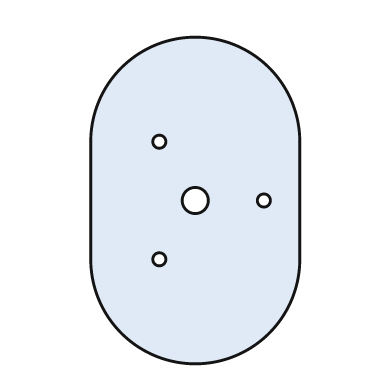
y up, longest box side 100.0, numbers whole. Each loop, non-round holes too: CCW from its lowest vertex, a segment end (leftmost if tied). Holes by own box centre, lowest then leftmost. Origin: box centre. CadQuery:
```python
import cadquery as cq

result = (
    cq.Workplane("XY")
    .moveTo(-32.0, -18.0)
    .threePointArc((0.0, -50.0), (32.0, -18.0))
    .lineTo(32.0, 18.0)
    .threePointArc((0.0, 50.0), (-32.0, 18.0))
    .close()
    .moveTo(-11.0, -18.0)
    .circle(2.0)
    .moveTo(0.0, 0.0)
    .circle(4.0)
    .moveTo(21.0, 0.0)
    .circle(2.0)
    .moveTo(-11.0, 18.0)
    .circle(2.0)
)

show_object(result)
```